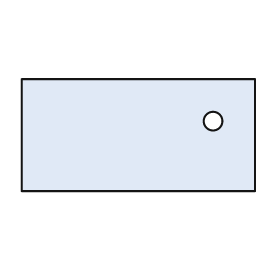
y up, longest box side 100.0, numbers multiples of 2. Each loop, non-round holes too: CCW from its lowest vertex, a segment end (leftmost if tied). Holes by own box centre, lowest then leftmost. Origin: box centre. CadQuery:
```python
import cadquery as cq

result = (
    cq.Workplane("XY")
    .moveTo(-50.0, -24.0)
    .lineTo(50.0, -24.0)
    .lineTo(50.0, 24.0)
    .lineTo(-50.0, 24.0)
    .close()
    .moveTo(32.0, 6.0)
    .circle(4.0)
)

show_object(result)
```